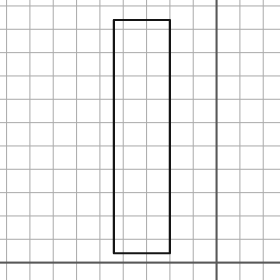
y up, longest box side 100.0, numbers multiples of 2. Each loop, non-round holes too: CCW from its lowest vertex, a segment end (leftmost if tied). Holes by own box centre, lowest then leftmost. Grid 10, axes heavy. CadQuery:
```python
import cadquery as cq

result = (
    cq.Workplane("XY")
    .moveTo(-44.0, 4.0)
    .lineTo(-20.0, 4.0)
    .lineTo(-20.0, 104.0)
    .lineTo(-44.0, 104.0)
    .close()
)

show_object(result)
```